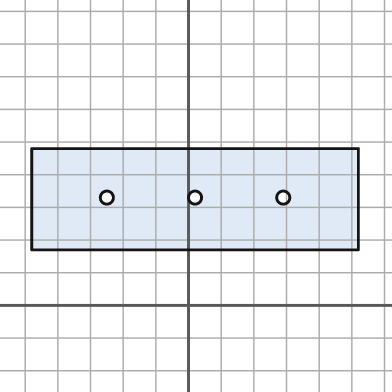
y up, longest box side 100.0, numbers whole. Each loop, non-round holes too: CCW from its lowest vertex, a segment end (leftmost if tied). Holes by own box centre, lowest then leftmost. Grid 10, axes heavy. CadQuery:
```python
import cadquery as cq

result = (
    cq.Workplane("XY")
    .moveTo(-48.0, 17.0)
    .lineTo(52.0, 17.0)
    .lineTo(52.0, 48.0)
    .lineTo(-48.0, 48.0)
    .close()
    .moveTo(-25.0, 33.0)
    .circle(2.0)
    .moveTo(2.0, 33.0)
    .circle(2.0)
    .moveTo(29.0, 33.0)
    .circle(2.0)
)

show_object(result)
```